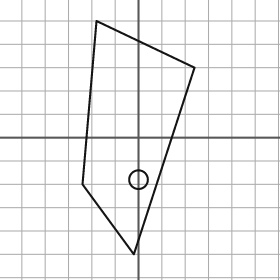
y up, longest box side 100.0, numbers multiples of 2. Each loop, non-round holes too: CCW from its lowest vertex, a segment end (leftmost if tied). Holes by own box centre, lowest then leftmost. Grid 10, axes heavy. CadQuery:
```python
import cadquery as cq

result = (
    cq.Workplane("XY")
    .moveTo(-2.0, -50.0)
    .lineTo(24.0, 30.0)
    .lineTo(-18.0, 50.0)
    .lineTo(-24.0, -20.0)
    .close()
    .moveTo(0.0, -18.0)
    .circle(4.0)
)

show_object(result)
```